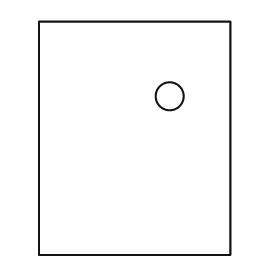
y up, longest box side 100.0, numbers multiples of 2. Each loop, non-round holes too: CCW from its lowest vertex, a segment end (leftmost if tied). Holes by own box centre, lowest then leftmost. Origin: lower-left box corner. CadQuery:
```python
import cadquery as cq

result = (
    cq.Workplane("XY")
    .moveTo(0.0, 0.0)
    .lineTo(82.0, 0.0)
    .lineTo(82.0, 100.0)
    .lineTo(0.0, 100.0)
    .close()
    .moveTo(56.0, 68.0)
    .circle(6.0)
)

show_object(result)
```